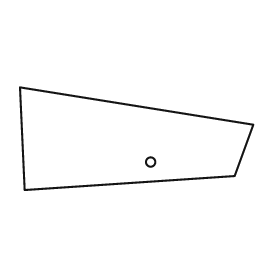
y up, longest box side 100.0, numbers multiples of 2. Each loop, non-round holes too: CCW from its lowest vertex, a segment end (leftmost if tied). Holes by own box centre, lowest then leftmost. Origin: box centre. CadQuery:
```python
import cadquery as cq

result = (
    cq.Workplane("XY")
    .moveTo(-48.0, -22.0)
    .lineTo(42.0, -16.0)
    .lineTo(50.0, 6.0)
    .lineTo(-50.0, 22.0)
    .close()
    .moveTo(6.0, -10.0)
    .circle(2.0)
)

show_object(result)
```